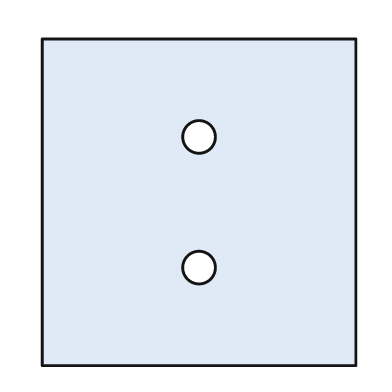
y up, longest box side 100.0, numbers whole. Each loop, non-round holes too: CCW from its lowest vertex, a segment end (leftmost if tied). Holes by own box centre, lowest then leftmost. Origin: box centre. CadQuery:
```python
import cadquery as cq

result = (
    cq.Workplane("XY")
    .moveTo(-48.0, -50.0)
    .lineTo(48.0, -50.0)
    .lineTo(48.0, 50.0)
    .lineTo(-48.0, 50.0)
    .close()
    .moveTo(0.0, -20.0)
    .circle(5.0)
    .moveTo(0.0, 20.0)
    .circle(5.0)
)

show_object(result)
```